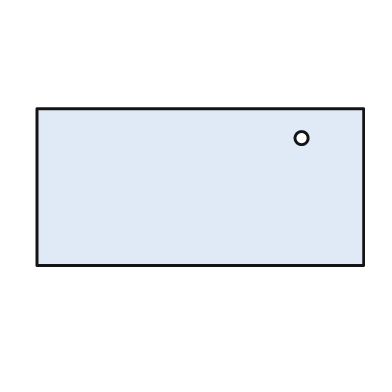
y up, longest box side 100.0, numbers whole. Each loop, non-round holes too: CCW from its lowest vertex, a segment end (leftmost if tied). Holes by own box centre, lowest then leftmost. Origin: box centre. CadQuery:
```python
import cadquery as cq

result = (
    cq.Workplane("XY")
    .moveTo(-50.0, -24.0)
    .lineTo(50.0, -24.0)
    .lineTo(50.0, 24.0)
    .lineTo(-50.0, 24.0)
    .close()
    .moveTo(31.0, 15.0)
    .circle(2.0)
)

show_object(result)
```